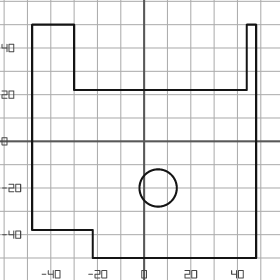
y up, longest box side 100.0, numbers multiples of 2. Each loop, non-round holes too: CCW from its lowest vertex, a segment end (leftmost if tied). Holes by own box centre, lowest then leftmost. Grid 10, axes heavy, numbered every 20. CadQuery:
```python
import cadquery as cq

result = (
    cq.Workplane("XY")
    .moveTo(-22.0, -50.0)
    .lineTo(48.0, -50.0)
    .lineTo(48.0, 50.0)
    .lineTo(44.0, 50.0)
    .lineTo(44.0, 22.0)
    .lineTo(-30.0, 22.0)
    .lineTo(-30.0, 50.0)
    .lineTo(-48.0, 50.0)
    .lineTo(-48.0, -38.0)
    .lineTo(-22.0, -38.0)
    .close()
    .moveTo(6.0, -20.0)
    .circle(8.0)
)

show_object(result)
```